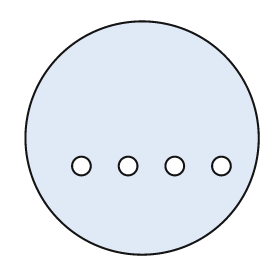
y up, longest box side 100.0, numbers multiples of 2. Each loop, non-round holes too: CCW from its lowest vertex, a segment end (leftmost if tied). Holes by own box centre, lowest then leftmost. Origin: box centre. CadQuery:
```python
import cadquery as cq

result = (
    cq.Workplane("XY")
    .moveTo(0.0, 0.0)
    .circle(50.0)
    .moveTo(-26.0, -12.0)
    .circle(4.0)
    .moveTo(-6.0, -12.0)
    .circle(4.0)
    .moveTo(14.0, -12.0)
    .circle(4.0)
    .moveTo(34.0, -12.0)
    .circle(4.0)
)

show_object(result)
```